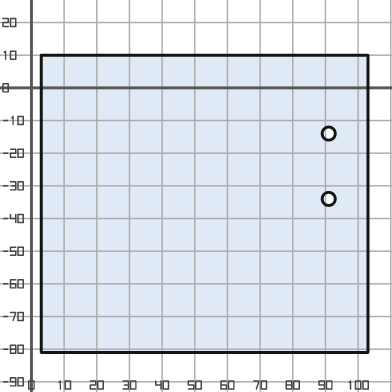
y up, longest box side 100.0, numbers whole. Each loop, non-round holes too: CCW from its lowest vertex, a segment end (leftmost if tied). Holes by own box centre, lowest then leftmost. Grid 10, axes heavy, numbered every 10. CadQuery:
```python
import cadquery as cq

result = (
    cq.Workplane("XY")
    .moveTo(3.0, -81.0)
    .lineTo(103.0, -81.0)
    .lineTo(103.0, 10.0)
    .lineTo(3.0, 10.0)
    .close()
    .moveTo(91.0, -34.0)
    .circle(2.0)
    .moveTo(91.0, -14.0)
    .circle(2.0)
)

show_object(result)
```